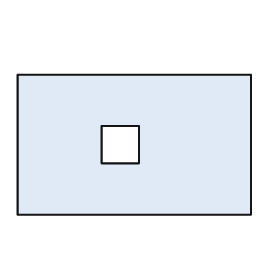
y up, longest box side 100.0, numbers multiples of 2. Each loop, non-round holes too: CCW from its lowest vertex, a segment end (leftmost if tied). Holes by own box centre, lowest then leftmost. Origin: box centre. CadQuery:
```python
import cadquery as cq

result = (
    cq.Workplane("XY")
    .moveTo(-50.0, -30.0)
    .lineTo(50.0, -30.0)
    .lineTo(50.0, 30.0)
    .lineTo(-50.0, 30.0)
    .close()
    .moveTo(-14.0, -8.0)
    .lineTo(2.0, -8.0)
    .lineTo(2.0, 8.0)
    .lineTo(-14.0, 8.0)
    .close()
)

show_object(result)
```